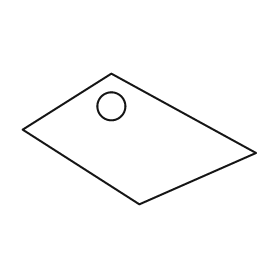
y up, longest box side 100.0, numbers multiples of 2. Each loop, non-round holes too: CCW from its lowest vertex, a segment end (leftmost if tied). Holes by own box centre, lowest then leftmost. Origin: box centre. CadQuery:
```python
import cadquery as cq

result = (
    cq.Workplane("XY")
    .moveTo(0.0, -28.0)
    .lineTo(50.0, -6.0)
    .lineTo(-12.0, 28.0)
    .lineTo(-50.0, 4.0)
    .close()
    .moveTo(-12.0, 14.0)
    .circle(6.0)
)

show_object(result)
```